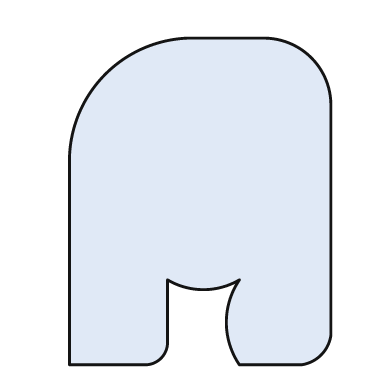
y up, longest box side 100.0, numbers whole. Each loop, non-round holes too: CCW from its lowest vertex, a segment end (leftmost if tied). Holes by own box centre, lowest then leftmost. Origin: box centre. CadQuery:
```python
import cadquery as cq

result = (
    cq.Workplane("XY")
    .moveTo(-40.0, -50.0)
    .lineTo(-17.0, -50.0)
    .threePointArc((-12.0, -48.0), (-10.0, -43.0))
    .lineTo(-10.0, -24.0)
    .threePointArc((1.0, -27.0), (12.0, -24.0))
    .threePointArc((8.0, -37.0), (12.0, -50.0))
    .lineTo(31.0, -50.0)
    .threePointArc((37.0, -47.0), (40.0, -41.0))
    .lineTo(40.0, 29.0)
    .threePointArc((34.0, 44.0), (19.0, 50.0))
    .lineTo(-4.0, 50.0)
    .threePointArc((-29.0, 39.0), (-40.0, 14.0))
    .close()
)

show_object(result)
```